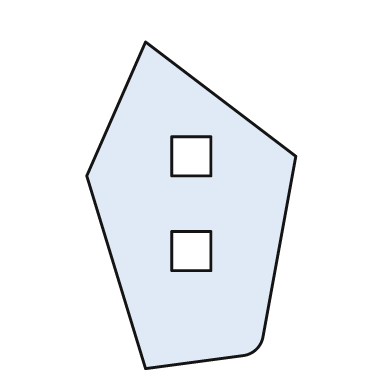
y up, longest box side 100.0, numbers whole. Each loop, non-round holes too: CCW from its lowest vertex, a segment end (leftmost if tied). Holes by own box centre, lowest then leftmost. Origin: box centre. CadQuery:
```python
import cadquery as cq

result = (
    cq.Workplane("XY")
    .moveTo(-14.0, -50.0)
    .lineTo(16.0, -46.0)
    .threePointArc((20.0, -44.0), (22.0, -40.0))
    .lineTo(32.0, 15.0)
    .lineTo(-14.0, 50.0)
    .lineTo(-32.0, 9.0)
    .close()
    .moveTo(-6.0, -20.0)
    .lineTo(6.0, -20.0)
    .lineTo(6.0, -8.0)
    .lineTo(-6.0, -8.0)
    .close()
    .moveTo(-6.0, 9.0)
    .lineTo(6.0, 9.0)
    .lineTo(6.0, 21.0)
    .lineTo(-6.0, 21.0)
    .close()
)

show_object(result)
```